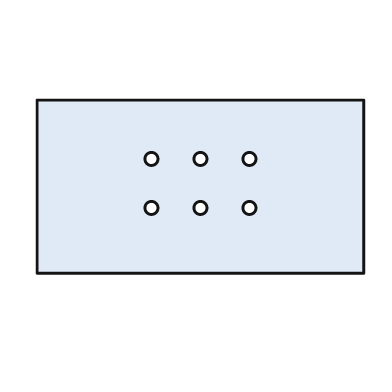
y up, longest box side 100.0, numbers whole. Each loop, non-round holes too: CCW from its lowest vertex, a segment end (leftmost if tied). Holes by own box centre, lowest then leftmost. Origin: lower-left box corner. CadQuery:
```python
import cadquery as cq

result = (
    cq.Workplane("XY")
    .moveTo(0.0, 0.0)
    .lineTo(100.0, 0.0)
    .lineTo(100.0, 53.0)
    .lineTo(0.0, 53.0)
    .close()
    .moveTo(35.0, 20.0)
    .circle(2.0)
    .moveTo(50.0, 20.0)
    .circle(2.0)
    .moveTo(65.0, 20.0)
    .circle(2.0)
    .moveTo(35.0, 35.0)
    .circle(2.0)
    .moveTo(50.0, 35.0)
    .circle(2.0)
    .moveTo(65.0, 35.0)
    .circle(2.0)
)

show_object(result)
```